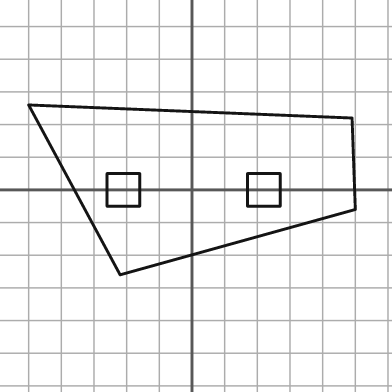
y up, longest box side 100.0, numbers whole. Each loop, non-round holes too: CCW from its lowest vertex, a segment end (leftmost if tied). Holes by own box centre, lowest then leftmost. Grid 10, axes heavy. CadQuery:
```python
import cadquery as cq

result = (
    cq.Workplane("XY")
    .moveTo(-22.0, -26.0)
    .lineTo(50.0, -6.0)
    .lineTo(49.0, 22.0)
    .lineTo(-50.0, 26.0)
    .close()
    .moveTo(-26.0, -5.0)
    .lineTo(-16.0, -5.0)
    .lineTo(-16.0, 5.0)
    .lineTo(-26.0, 5.0)
    .close()
    .moveTo(17.0, -5.0)
    .lineTo(27.0, -5.0)
    .lineTo(27.0, 5.0)
    .lineTo(17.0, 5.0)
    .close()
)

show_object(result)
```